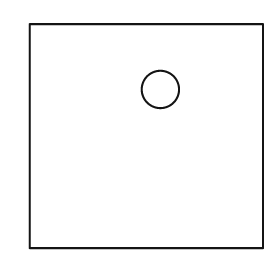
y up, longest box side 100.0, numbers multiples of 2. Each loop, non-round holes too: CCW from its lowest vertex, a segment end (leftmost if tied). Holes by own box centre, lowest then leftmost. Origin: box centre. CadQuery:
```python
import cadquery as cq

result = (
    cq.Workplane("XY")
    .moveTo(-50.0, -48.0)
    .lineTo(50.0, -48.0)
    .lineTo(50.0, 48.0)
    .lineTo(-50.0, 48.0)
    .close()
    .moveTo(6.0, 20.0)
    .circle(8.0)
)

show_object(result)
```